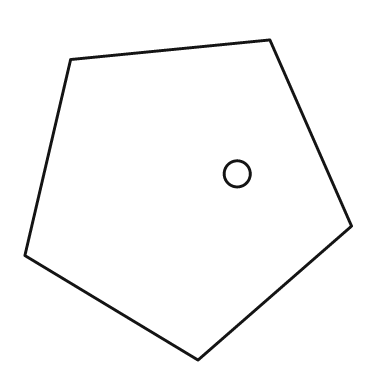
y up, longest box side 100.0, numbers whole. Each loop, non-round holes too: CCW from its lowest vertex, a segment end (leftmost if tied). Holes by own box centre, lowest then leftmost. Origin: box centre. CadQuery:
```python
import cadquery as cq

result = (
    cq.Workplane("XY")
    .moveTo(3.0, -49.0)
    .lineTo(50.0, -8.0)
    .lineTo(25.0, 49.0)
    .lineTo(-36.0, 43.0)
    .lineTo(-50.0, -17.0)
    .close()
    .moveTo(15.0, 8.0)
    .circle(4.0)
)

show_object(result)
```